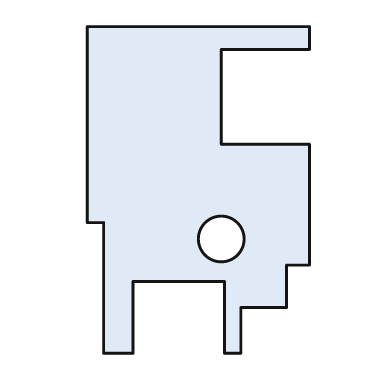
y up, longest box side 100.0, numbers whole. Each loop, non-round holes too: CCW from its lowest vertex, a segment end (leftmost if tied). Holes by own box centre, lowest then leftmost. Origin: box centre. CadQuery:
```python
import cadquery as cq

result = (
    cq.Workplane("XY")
    .moveTo(-29.0, -50.0)
    .lineTo(-20.0, -50.0)
    .lineTo(-20.0, -28.0)
    .lineTo(8.0, -28.0)
    .lineTo(8.0, -50.0)
    .lineTo(13.0, -50.0)
    .lineTo(13.0, -36.0)
    .lineTo(27.0, -36.0)
    .lineTo(27.0, -23.0)
    .lineTo(34.0, -23.0)
    .lineTo(34.0, 14.0)
    .lineTo(7.0, 14.0)
    .lineTo(7.0, 43.0)
    .lineTo(34.0, 43.0)
    .lineTo(34.0, 50.0)
    .lineTo(-34.0, 50.0)
    .lineTo(-34.0, -10.0)
    .lineTo(-29.0, -10.0)
    .close()
    .moveTo(7.0, -15.0)
    .circle(7.0)
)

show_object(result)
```